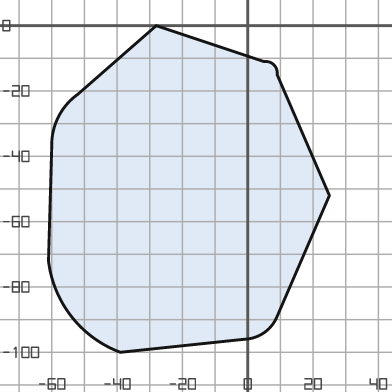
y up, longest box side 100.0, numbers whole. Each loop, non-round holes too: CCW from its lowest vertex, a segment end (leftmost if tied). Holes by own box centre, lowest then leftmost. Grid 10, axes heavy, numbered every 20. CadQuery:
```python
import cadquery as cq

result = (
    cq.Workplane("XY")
    .moveTo(-39.0, -100.0)
    .lineTo(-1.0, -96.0)
    .threePointArc((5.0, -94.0), (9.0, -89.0))
    .lineTo(25.0, -52.0)
    .lineTo(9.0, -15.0)
    .threePointArc((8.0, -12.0), (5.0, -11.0))
    .lineTo(-28.0, 0.0)
    .lineTo(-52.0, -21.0)
    .threePointArc((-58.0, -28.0), (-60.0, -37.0))
    .lineTo(-61.0, -72.0)
    .threePointArc((-54.0, -89.0), (-39.0, -100.0))
    .close()
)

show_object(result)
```